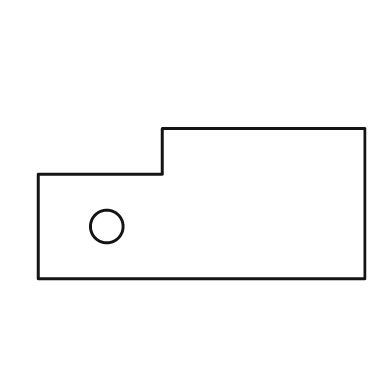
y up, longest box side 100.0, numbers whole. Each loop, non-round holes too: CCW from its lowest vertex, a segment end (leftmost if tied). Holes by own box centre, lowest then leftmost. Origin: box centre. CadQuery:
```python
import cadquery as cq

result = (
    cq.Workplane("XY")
    .moveTo(-50.0, -23.0)
    .lineTo(50.0, -23.0)
    .lineTo(50.0, 23.0)
    .lineTo(-12.0, 23.0)
    .lineTo(-12.0, 9.0)
    .lineTo(-50.0, 9.0)
    .close()
    .moveTo(-29.0, -7.0)
    .circle(5.0)
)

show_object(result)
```